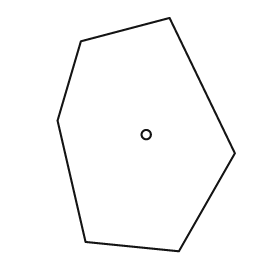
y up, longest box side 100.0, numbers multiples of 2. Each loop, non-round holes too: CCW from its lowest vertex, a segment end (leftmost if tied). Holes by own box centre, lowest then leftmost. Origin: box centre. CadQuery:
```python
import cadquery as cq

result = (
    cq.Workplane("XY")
    .moveTo(14.0, -50.0)
    .lineTo(38.0, -8.0)
    .lineTo(10.0, 50.0)
    .lineTo(-28.0, 40.0)
    .lineTo(-38.0, 6.0)
    .lineTo(-26.0, -46.0)
    .close()
    .moveTo(0.0, 0.0)
    .circle(2.0)
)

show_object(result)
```